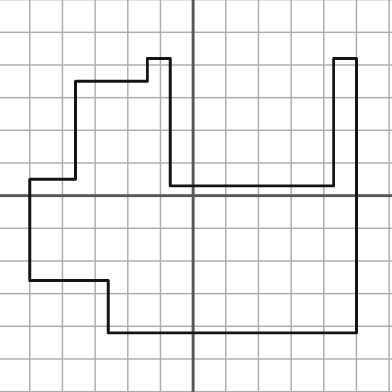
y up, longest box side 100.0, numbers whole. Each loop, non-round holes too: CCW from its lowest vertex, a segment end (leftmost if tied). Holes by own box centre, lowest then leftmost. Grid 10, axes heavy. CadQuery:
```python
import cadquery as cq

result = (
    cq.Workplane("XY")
    .moveTo(-26.0, -42.0)
    .lineTo(50.0, -42.0)
    .lineTo(50.0, 42.0)
    .lineTo(43.0, 42.0)
    .lineTo(43.0, 3.0)
    .lineTo(-7.0, 3.0)
    .lineTo(-7.0, 42.0)
    .lineTo(-14.0, 42.0)
    .lineTo(-14.0, 35.0)
    .lineTo(-36.0, 35.0)
    .lineTo(-36.0, 5.0)
    .lineTo(-50.0, 5.0)
    .lineTo(-50.0, -26.0)
    .lineTo(-26.0, -26.0)
    .close()
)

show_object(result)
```